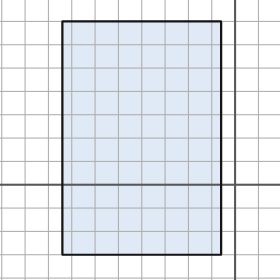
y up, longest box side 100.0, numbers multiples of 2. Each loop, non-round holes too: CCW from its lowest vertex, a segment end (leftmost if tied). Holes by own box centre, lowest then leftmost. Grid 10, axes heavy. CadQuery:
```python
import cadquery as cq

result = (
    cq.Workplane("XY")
    .moveTo(-74.0, -30.0)
    .lineTo(-6.0, -30.0)
    .lineTo(-6.0, 70.0)
    .lineTo(-74.0, 70.0)
    .close()
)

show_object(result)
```